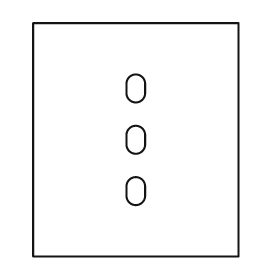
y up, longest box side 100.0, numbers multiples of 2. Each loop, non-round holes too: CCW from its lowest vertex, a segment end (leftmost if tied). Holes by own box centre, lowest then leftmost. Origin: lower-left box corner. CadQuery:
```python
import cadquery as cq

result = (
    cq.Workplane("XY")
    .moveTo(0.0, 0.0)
    .lineTo(88.0, 0.0)
    .lineTo(88.0, 100.0)
    .lineTo(0.0, 100.0)
    .close()
    .moveTo(40.0, 26.0)
    .threePointArc((44.0, 22.0), (48.0, 26.0))
    .lineTo(48.0, 30.0)
    .threePointArc((44.0, 34.0), (40.0, 30.0))
    .close()
    .moveTo(40.0, 48.0)
    .threePointArc((44.0, 44.0), (48.0, 48.0))
    .lineTo(48.0, 52.0)
    .threePointArc((44.0, 56.0), (40.0, 52.0))
    .close()
    .moveTo(40.0, 70.0)
    .threePointArc((44.0, 66.0), (48.0, 70.0))
    .lineTo(48.0, 74.0)
    .threePointArc((44.0, 78.0), (40.0, 74.0))
    .close()
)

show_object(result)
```